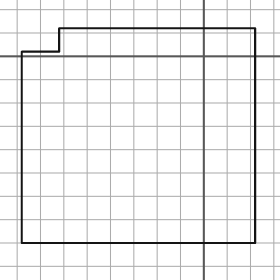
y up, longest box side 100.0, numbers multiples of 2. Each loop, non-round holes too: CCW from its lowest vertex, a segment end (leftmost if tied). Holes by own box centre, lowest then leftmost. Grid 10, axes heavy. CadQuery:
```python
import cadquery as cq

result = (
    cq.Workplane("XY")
    .moveTo(-78.0, -80.0)
    .lineTo(22.0, -80.0)
    .lineTo(22.0, 12.0)
    .lineTo(-62.0, 12.0)
    .lineTo(-62.0, 2.0)
    .lineTo(-78.0, 2.0)
    .close()
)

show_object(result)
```